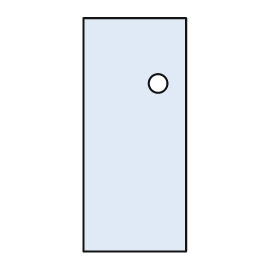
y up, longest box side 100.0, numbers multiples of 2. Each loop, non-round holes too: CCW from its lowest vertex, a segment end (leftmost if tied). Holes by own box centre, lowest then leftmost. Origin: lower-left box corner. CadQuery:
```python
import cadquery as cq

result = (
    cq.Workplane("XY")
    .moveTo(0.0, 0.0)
    .lineTo(44.0, 0.0)
    .lineTo(44.0, 100.0)
    .lineTo(0.0, 100.0)
    .close()
    .moveTo(32.0, 72.0)
    .circle(4.0)
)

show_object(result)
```